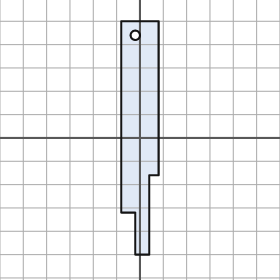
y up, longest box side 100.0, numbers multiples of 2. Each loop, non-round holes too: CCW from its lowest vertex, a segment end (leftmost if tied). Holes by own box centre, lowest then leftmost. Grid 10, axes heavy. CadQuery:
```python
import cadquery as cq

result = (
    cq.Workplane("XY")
    .moveTo(-2.0, -50.0)
    .lineTo(4.0, -50.0)
    .lineTo(4.0, -16.0)
    .lineTo(8.0, -16.0)
    .lineTo(8.0, 50.0)
    .lineTo(-8.0, 50.0)
    .lineTo(-8.0, -32.0)
    .lineTo(-2.0, -32.0)
    .close()
    .moveTo(-2.0, 44.0)
    .circle(2.0)
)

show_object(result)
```